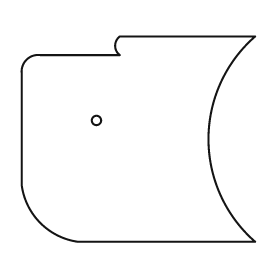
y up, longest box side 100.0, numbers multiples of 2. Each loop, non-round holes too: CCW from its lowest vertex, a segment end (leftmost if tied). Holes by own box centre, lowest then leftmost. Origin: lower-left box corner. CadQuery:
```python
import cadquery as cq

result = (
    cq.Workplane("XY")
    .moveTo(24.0, 0.0)
    .lineTo(100.0, 0.0)
    .threePointArc((80.0, 44.0), (100.0, 88.0))
    .lineTo(42.0, 88.0)
    .threePointArc((40.0, 84.0), (42.0, 80.0))
    .lineTo(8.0, 80.0)
    .threePointArc((2.0, 78.0), (0.0, 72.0))
    .lineTo(0.0, 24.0)
    .threePointArc((8.0, 8.0), (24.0, 0.0))
    .close()
    .moveTo(32.0, 52.0)
    .circle(2.0)
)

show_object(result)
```